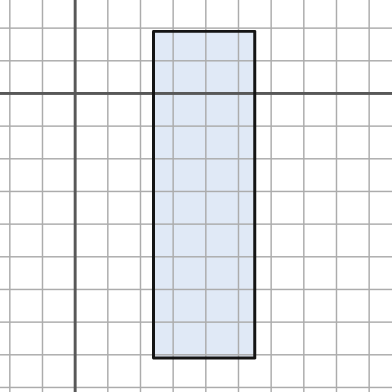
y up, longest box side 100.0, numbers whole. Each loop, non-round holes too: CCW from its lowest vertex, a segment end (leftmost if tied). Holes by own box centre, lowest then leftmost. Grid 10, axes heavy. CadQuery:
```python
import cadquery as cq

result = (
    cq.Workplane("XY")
    .moveTo(24.0, -81.0)
    .lineTo(55.0, -81.0)
    .lineTo(55.0, 19.0)
    .lineTo(24.0, 19.0)
    .close()
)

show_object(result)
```